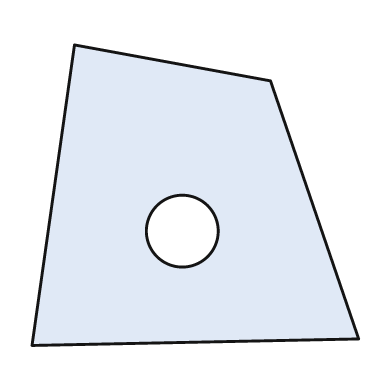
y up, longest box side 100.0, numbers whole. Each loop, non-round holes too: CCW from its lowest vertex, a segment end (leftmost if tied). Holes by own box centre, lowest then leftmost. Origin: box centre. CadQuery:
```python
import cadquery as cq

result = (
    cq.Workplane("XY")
    .moveTo(-50.0, -46.0)
    .lineTo(50.0, -44.0)
    .lineTo(23.0, 35.0)
    .lineTo(-37.0, 46.0)
    .close()
    .moveTo(-4.0, -11.0)
    .circle(11.0)
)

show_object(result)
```